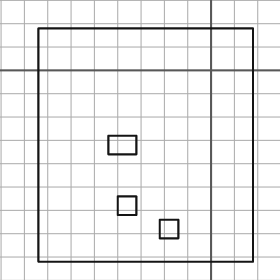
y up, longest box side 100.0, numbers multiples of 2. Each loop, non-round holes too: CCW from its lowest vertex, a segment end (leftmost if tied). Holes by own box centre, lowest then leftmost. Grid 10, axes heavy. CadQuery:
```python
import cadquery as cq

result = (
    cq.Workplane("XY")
    .moveTo(-74.0, -82.0)
    .lineTo(18.0, -82.0)
    .lineTo(18.0, 18.0)
    .lineTo(-74.0, 18.0)
    .close()
    .moveTo(-22.0, -72.0)
    .lineTo(-14.0, -72.0)
    .lineTo(-14.0, -64.0)
    .lineTo(-22.0, -64.0)
    .close()
    .moveTo(-40.0, -62.0)
    .lineTo(-32.0, -62.0)
    .lineTo(-32.0, -54.0)
    .lineTo(-40.0, -54.0)
    .close()
    .moveTo(-44.0, -36.0)
    .lineTo(-32.0, -36.0)
    .lineTo(-32.0, -28.0)
    .lineTo(-44.0, -28.0)
    .close()
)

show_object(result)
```